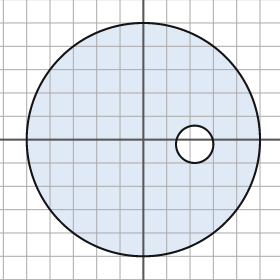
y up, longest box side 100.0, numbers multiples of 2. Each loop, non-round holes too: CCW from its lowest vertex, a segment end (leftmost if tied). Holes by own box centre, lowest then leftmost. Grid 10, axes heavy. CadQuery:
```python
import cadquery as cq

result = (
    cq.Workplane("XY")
    .moveTo(0.0, 0.0)
    .circle(50.0)
    .moveTo(22.0, -2.0)
    .circle(8.0)
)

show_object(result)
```